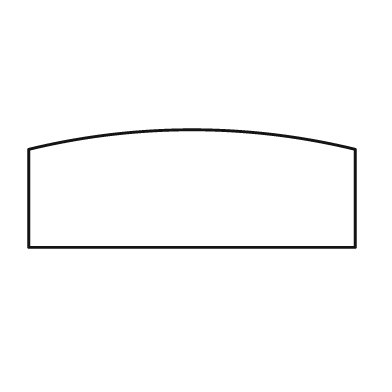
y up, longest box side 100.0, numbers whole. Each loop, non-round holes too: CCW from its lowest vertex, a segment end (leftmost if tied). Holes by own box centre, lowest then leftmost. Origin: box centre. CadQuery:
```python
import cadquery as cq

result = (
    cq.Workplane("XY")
    .moveTo(-50.0, -18.0)
    .lineTo(50.0, -18.0)
    .lineTo(50.0, 12.0)
    .threePointArc((0.0, 18.0), (-50.0, 12.0))
    .close()
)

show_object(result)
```